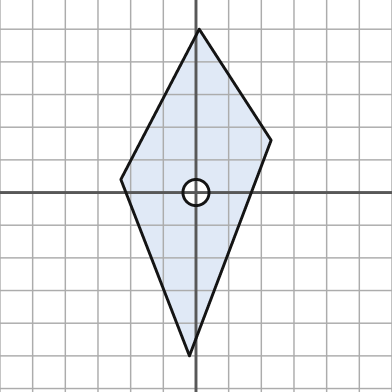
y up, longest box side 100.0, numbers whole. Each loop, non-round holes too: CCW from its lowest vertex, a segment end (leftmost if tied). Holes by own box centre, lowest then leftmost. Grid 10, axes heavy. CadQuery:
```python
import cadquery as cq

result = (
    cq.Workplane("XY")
    .moveTo(-2.0, -50.0)
    .lineTo(23.0, 16.0)
    .lineTo(1.0, 50.0)
    .lineTo(-23.0, 4.0)
    .close()
    .moveTo(0.0, 0.0)
    .circle(4.0)
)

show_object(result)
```